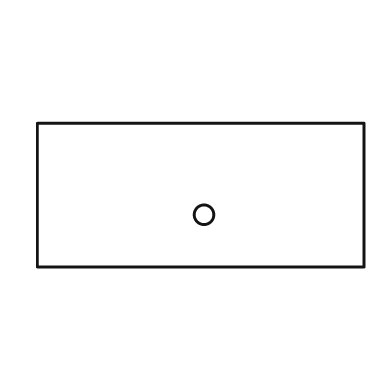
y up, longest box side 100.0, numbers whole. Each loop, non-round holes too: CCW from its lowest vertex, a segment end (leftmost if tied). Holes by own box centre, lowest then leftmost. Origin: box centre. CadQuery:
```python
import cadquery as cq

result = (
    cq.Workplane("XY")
    .moveTo(-50.0, -22.0)
    .lineTo(50.0, -22.0)
    .lineTo(50.0, 22.0)
    .lineTo(-50.0, 22.0)
    .close()
    .moveTo(1.0, -6.0)
    .circle(3.0)
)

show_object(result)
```